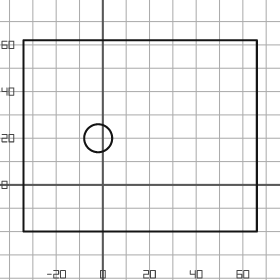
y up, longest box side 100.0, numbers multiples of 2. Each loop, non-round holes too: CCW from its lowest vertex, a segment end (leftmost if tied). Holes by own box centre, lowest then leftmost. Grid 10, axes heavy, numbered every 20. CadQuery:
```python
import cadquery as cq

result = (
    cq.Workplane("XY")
    .moveTo(-34.0, -20.0)
    .lineTo(66.0, -20.0)
    .lineTo(66.0, 62.0)
    .lineTo(-34.0, 62.0)
    .close()
    .moveTo(-2.0, 20.0)
    .circle(6.0)
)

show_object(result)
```